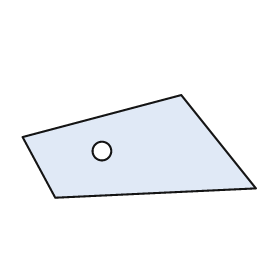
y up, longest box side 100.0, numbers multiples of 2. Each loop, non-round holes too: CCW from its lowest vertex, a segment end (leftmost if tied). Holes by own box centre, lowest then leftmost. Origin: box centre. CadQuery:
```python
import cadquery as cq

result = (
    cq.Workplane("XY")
    .moveTo(-36.0, -22.0)
    .lineTo(50.0, -18.0)
    .lineTo(18.0, 22.0)
    .lineTo(-50.0, 4.0)
    .close()
    .moveTo(-16.0, -2.0)
    .circle(4.0)
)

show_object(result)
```